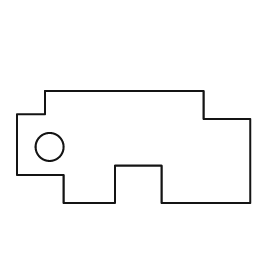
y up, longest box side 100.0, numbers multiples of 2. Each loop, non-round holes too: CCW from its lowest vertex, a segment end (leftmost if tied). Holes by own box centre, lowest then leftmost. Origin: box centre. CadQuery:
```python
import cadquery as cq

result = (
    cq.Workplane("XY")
    .moveTo(-30.0, -24.0)
    .lineTo(-8.0, -24.0)
    .lineTo(-8.0, -8.0)
    .lineTo(12.0, -8.0)
    .lineTo(12.0, -24.0)
    .lineTo(50.0, -24.0)
    .lineTo(50.0, 12.0)
    .lineTo(30.0, 12.0)
    .lineTo(30.0, 24.0)
    .lineTo(-38.0, 24.0)
    .lineTo(-38.0, 14.0)
    .lineTo(-50.0, 14.0)
    .lineTo(-50.0, -12.0)
    .lineTo(-30.0, -12.0)
    .close()
    .moveTo(-36.0, 0.0)
    .circle(6.0)
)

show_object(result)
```